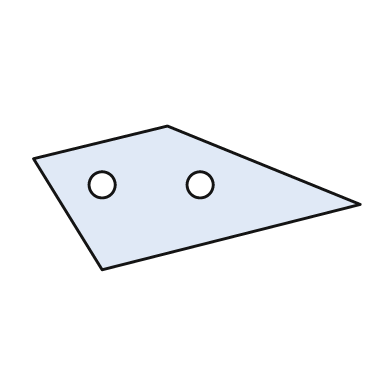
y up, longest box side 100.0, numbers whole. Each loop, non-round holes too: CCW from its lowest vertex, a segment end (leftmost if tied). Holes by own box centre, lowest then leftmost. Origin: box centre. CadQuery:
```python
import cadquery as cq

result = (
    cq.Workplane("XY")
    .moveTo(-29.0, -22.0)
    .lineTo(50.0, -2.0)
    .lineTo(-9.0, 22.0)
    .lineTo(-50.0, 12.0)
    .close()
    .moveTo(-29.0, 4.0)
    .circle(4.0)
    .moveTo(1.0, 4.0)
    .circle(4.0)
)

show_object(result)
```